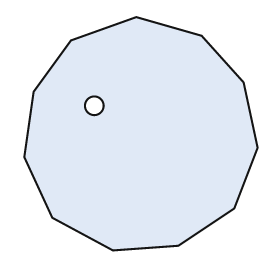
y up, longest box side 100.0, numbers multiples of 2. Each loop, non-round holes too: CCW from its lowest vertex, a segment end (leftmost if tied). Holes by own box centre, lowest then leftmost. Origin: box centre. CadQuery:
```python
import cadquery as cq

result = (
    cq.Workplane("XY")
    .moveTo(-12.0, -50.0)
    .lineTo(16.0, -48.0)
    .lineTo(40.0, -32.0)
    .lineTo(50.0, -6.0)
    .lineTo(44.0, 22.0)
    .lineTo(26.0, 42.0)
    .lineTo(-2.0, 50.0)
    .lineTo(-30.0, 40.0)
    .lineTo(-46.0, 18.0)
    .lineTo(-50.0, -10.0)
    .lineTo(-38.0, -36.0)
    .close()
    .moveTo(-20.0, 12.0)
    .circle(4.0)
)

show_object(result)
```